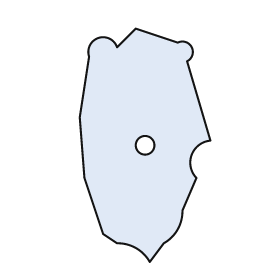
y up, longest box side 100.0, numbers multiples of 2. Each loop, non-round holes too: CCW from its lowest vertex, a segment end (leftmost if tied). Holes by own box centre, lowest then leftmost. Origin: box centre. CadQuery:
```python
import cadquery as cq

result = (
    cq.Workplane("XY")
    .moveTo(2.0, -50.0)
    .lineTo(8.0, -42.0)
    .threePointArc((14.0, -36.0), (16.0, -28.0))
    .lineTo(22.0, -14.0)
    .threePointArc((20.0, -4.0), (28.0, 2.0))
    .lineTo(18.0, 36.0)
    .threePointArc((20.0, 42.0), (14.0, 44.0))
    .lineTo(-4.0, 50.0)
    .lineTo(-12.0, 42.0)
    .threePointArc((-20.0, 46.0), (-24.0, 38.0))
    .lineTo(-28.0, 12.0)
    .lineTo(-26.0, -14.0)
    .lineTo(-18.0, -38.0)
    .lineTo(-12.0, -42.0)
    .threePointArc((-4.0, -44.0), (2.0, -50.0))
    .close()
    .moveTo(0.0, 0.0)
    .circle(4.0)
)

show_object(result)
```